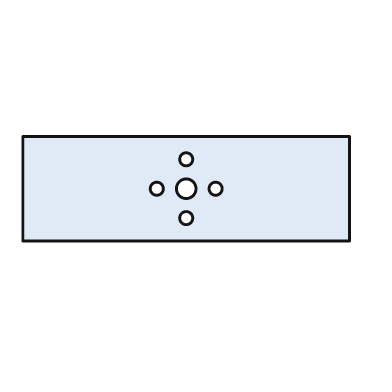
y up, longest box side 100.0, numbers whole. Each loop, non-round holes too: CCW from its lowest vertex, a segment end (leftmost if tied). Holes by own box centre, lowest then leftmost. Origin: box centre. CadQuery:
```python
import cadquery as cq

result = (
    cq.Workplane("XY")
    .moveTo(-50.0, -16.0)
    .lineTo(50.0, -16.0)
    .lineTo(50.0, 16.0)
    .lineTo(-50.0, 16.0)
    .close()
    .moveTo(0.0, -9.0)
    .circle(2.0)
    .moveTo(-9.0, 0.0)
    .circle(2.0)
    .moveTo(0.0, 0.0)
    .circle(3.0)
    .moveTo(9.0, 0.0)
    .circle(2.0)
    .moveTo(0.0, 9.0)
    .circle(2.0)
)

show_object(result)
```